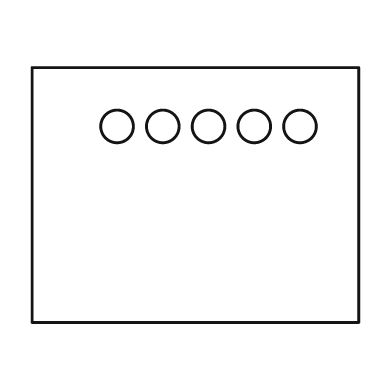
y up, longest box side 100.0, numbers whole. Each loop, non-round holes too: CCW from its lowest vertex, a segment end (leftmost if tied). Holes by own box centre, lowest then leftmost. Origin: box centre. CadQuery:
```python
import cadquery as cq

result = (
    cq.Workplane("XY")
    .moveTo(-50.0, -39.0)
    .lineTo(50.0, -39.0)
    .lineTo(50.0, 39.0)
    .lineTo(-50.0, 39.0)
    .close()
    .moveTo(-24.0, 21.0)
    .circle(5.0)
    .moveTo(-10.0, 21.0)
    .circle(5.0)
    .moveTo(4.0, 21.0)
    .circle(5.0)
    .moveTo(18.0, 21.0)
    .circle(5.0)
    .moveTo(32.0, 21.0)
    .circle(5.0)
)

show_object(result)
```